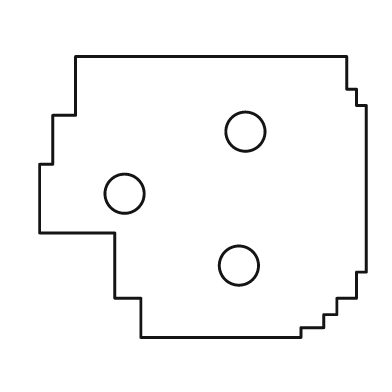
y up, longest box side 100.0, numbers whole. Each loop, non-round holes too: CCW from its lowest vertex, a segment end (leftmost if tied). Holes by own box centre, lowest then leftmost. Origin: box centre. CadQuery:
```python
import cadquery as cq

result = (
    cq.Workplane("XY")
    .moveTo(-19.0, -43.0)
    .lineTo(30.0, -43.0)
    .lineTo(30.0, -40.0)
    .lineTo(37.0, -40.0)
    .lineTo(37.0, -36.0)
    .lineTo(41.0, -36.0)
    .lineTo(41.0, -31.0)
    .lineTo(47.0, -31.0)
    .lineTo(47.0, -23.0)
    .lineTo(50.0, -23.0)
    .lineTo(50.0, 28.0)
    .lineTo(47.0, 28.0)
    .lineTo(47.0, 33.0)
    .lineTo(44.0, 33.0)
    .lineTo(44.0, 43.0)
    .lineTo(-39.0, 43.0)
    .lineTo(-39.0, 25.0)
    .lineTo(-46.0, 25.0)
    .lineTo(-46.0, 10.0)
    .lineTo(-50.0, 10.0)
    .lineTo(-50.0, -11.0)
    .lineTo(-27.0, -11.0)
    .lineTo(-27.0, -31.0)
    .lineTo(-19.0, -31.0)
    .close()
    .moveTo(11.0, -21.0)
    .circle(6.0)
    .moveTo(-24.0, 1.0)
    .circle(6.0)
    .moveTo(13.0, 20.0)
    .circle(6.0)
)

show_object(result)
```